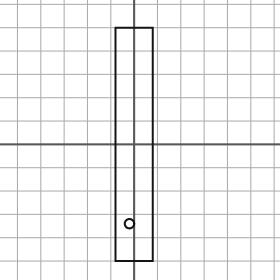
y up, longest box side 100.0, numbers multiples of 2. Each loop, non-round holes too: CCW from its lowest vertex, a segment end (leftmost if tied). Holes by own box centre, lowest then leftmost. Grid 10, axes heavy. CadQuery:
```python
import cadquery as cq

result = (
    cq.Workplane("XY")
    .moveTo(-8.0, -50.0)
    .lineTo(8.0, -50.0)
    .lineTo(8.0, 50.0)
    .lineTo(-8.0, 50.0)
    .close()
    .moveTo(-2.0, -34.0)
    .circle(2.0)
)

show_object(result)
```